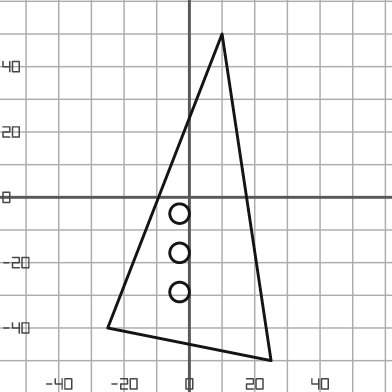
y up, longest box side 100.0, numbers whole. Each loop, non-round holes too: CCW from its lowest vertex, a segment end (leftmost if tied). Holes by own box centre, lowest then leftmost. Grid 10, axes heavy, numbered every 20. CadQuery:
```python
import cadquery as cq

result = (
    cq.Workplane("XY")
    .moveTo(25.0, -50.0)
    .lineTo(10.0, 50.0)
    .lineTo(-25.0, -40.0)
    .close()
    .moveTo(-3.0, -29.0)
    .circle(3.0)
    .moveTo(-3.0, -17.0)
    .circle(3.0)
    .moveTo(-3.0, -5.0)
    .circle(3.0)
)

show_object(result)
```